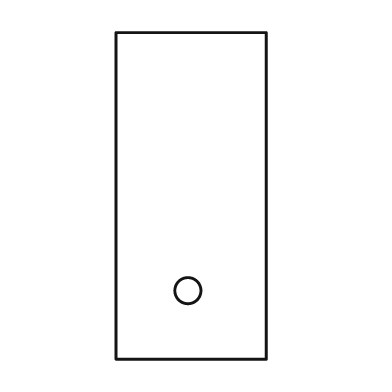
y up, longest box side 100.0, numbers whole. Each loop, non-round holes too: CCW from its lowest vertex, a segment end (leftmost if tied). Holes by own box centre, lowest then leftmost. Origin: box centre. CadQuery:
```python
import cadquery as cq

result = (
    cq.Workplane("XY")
    .moveTo(-23.0, -50.0)
    .lineTo(23.0, -50.0)
    .lineTo(23.0, 50.0)
    .lineTo(-23.0, 50.0)
    .close()
    .moveTo(-1.0, -29.0)
    .circle(4.0)
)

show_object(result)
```